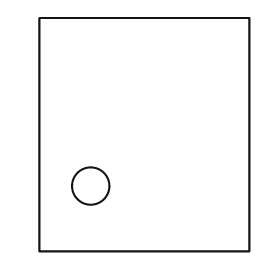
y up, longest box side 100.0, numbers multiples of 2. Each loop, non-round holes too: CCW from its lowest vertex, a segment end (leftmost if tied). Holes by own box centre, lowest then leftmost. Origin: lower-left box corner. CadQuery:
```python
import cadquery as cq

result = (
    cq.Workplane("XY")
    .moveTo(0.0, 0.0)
    .lineTo(90.0, 0.0)
    .lineTo(90.0, 100.0)
    .lineTo(0.0, 100.0)
    .close()
    .moveTo(22.0, 28.0)
    .circle(8.0)
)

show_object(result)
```